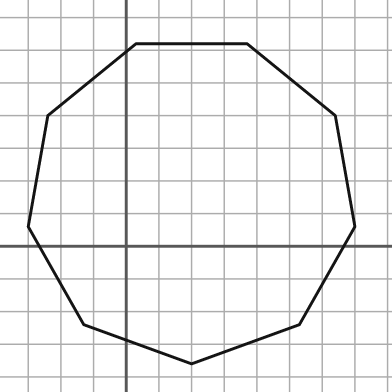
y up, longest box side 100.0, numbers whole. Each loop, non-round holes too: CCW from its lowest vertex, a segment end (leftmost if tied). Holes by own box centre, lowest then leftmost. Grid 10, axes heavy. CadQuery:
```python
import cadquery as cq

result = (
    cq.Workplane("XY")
    .moveTo(20.0, -36.0)
    .lineTo(53.0, -24.0)
    .lineTo(70.0, 6.0)
    .lineTo(64.0, 40.0)
    .lineTo(37.0, 62.0)
    .lineTo(3.0, 62.0)
    .lineTo(-24.0, 40.0)
    .lineTo(-30.0, 6.0)
    .lineTo(-13.0, -24.0)
    .close()
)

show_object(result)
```